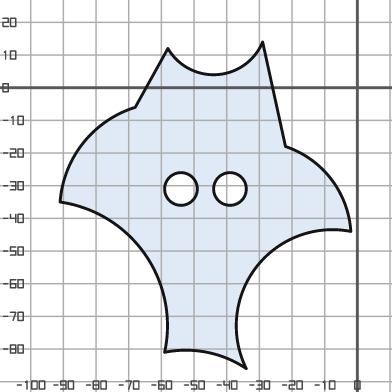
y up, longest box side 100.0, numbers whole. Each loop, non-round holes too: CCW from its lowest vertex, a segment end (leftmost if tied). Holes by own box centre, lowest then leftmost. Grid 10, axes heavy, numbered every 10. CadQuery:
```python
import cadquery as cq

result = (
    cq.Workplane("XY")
    .moveTo(-34.0, -86.0)
    .threePointArc((-31.0, -55.0), (-2.0, -44.0))
    .threePointArc((-8.0, -28.0), (-22.0, -18.0))
    .lineTo(-29.0, 14.0)
    .threePointArc((-43.0, 4.0), (-58.0, 12.0))
    .lineTo(-68.0, -6.0)
    .threePointArc((-84.0, -17.0), (-91.0, -35.0))
    .threePointArc((-65.0, -51.0), (-59.0, -81.0))
    .threePointArc((-46.0, -81.0), (-34.0, -86.0))
    .close()
    .moveTo(-54.0, -31.0)
    .circle(5.0)
    .moveTo(-39.0, -31.0)
    .circle(5.0)
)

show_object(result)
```